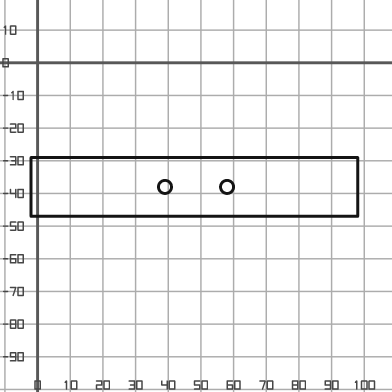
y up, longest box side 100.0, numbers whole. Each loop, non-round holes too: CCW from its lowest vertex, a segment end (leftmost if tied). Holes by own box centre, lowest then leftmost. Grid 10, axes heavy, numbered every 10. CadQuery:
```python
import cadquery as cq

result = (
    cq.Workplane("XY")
    .moveTo(-2.0, -47.0)
    .lineTo(98.0, -47.0)
    .lineTo(98.0, -29.0)
    .lineTo(-2.0, -29.0)
    .close()
    .moveTo(39.0, -38.0)
    .circle(2.0)
    .moveTo(58.0, -38.0)
    .circle(2.0)
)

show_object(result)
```